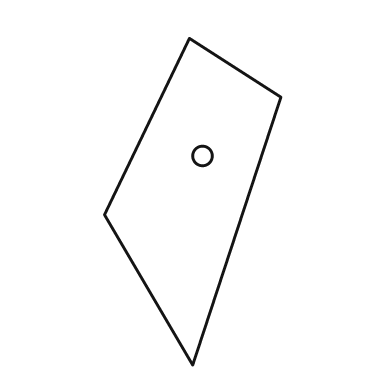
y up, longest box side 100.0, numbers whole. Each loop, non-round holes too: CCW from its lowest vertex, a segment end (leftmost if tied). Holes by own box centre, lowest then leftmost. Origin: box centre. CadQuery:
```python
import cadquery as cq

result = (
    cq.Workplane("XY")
    .moveTo(0.0, -50.0)
    .lineTo(27.0, 32.0)
    .lineTo(-1.0, 50.0)
    .lineTo(-27.0, -4.0)
    .close()
    .moveTo(3.0, 14.0)
    .circle(3.0)
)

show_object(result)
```